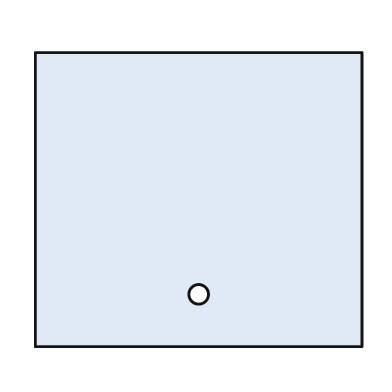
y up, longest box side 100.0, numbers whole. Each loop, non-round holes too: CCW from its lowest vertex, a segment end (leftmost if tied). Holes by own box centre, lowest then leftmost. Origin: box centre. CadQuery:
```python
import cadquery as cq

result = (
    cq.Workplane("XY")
    .moveTo(-50.0, -45.0)
    .lineTo(50.0, -45.0)
    .lineTo(50.0, 45.0)
    .lineTo(-50.0, 45.0)
    .close()
    .moveTo(0.0, -29.0)
    .circle(3.0)
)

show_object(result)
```